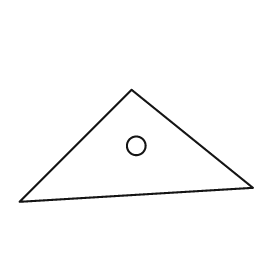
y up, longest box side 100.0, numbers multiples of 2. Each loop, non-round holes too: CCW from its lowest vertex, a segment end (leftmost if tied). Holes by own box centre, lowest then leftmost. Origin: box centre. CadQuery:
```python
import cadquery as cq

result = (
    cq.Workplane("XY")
    .moveTo(-50.0, -24.0)
    .lineTo(50.0, -18.0)
    .lineTo(-2.0, 24.0)
    .close()
    .moveTo(0.0, 0.0)
    .circle(4.0)
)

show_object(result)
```